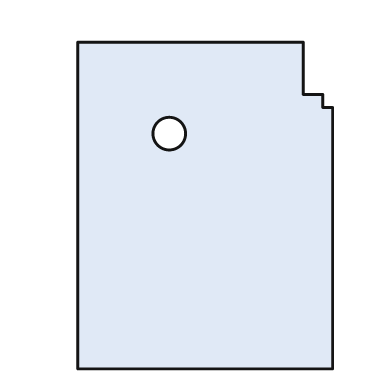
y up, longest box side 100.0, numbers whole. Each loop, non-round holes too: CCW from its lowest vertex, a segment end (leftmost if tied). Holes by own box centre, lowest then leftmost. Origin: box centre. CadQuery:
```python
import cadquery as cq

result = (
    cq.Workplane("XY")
    .moveTo(-39.0, -50.0)
    .lineTo(39.0, -50.0)
    .lineTo(39.0, 30.0)
    .lineTo(36.0, 30.0)
    .lineTo(36.0, 34.0)
    .lineTo(30.0, 34.0)
    .lineTo(30.0, 50.0)
    .lineTo(-39.0, 50.0)
    .close()
    .moveTo(-11.0, 22.0)
    .circle(5.0)
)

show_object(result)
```